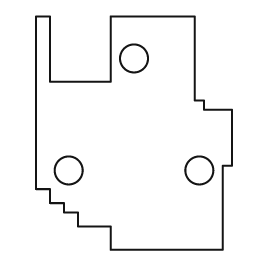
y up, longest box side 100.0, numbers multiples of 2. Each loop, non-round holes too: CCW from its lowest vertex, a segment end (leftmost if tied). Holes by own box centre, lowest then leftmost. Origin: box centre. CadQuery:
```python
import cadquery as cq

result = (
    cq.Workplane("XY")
    .moveTo(-10.0, -50.0)
    .lineTo(38.0, -50.0)
    .lineTo(38.0, -14.0)
    .lineTo(42.0, -14.0)
    .lineTo(42.0, 10.0)
    .lineTo(30.0, 10.0)
    .lineTo(30.0, 14.0)
    .lineTo(26.0, 14.0)
    .lineTo(26.0, 50.0)
    .lineTo(-10.0, 50.0)
    .lineTo(-10.0, 22.0)
    .lineTo(-36.0, 22.0)
    .lineTo(-36.0, 50.0)
    .lineTo(-42.0, 50.0)
    .lineTo(-42.0, -24.0)
    .lineTo(-36.0, -24.0)
    .lineTo(-36.0, -30.0)
    .lineTo(-30.0, -30.0)
    .lineTo(-30.0, -34.0)
    .lineTo(-24.0, -34.0)
    .lineTo(-24.0, -40.0)
    .lineTo(-10.0, -40.0)
    .close()
    .moveTo(-28.0, -16.0)
    .circle(6.0)
    .moveTo(28.0, -16.0)
    .circle(6.0)
    .moveTo(0.0, 32.0)
    .circle(6.0)
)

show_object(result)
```